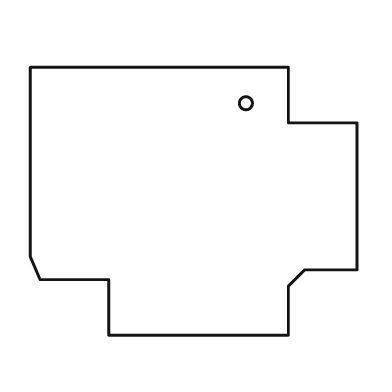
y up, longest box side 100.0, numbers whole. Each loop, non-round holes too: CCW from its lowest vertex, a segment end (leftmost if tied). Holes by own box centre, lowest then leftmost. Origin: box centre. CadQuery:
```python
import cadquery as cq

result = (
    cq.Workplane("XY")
    .moveTo(-26.0, -41.0)
    .lineTo(29.0, -41.0)
    .lineTo(29.0, -26.0)
    .lineTo(34.0, -21.0)
    .lineTo(50.0, -21.0)
    .lineTo(50.0, 24.0)
    .lineTo(29.0, 24.0)
    .lineTo(29.0, 41.0)
    .lineTo(-50.0, 41.0)
    .lineTo(-50.0, -17.0)
    .lineTo(-47.0, -24.0)
    .lineTo(-26.0, -24.0)
    .close()
    .moveTo(16.0, 30.0)
    .circle(2.0)
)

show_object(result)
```